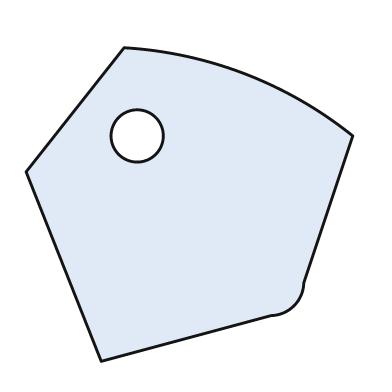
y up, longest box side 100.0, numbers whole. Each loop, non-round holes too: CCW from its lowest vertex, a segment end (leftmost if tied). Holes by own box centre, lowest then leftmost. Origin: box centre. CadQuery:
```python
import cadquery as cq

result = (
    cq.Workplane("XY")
    .moveTo(-27.0, -48.0)
    .lineTo(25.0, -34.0)
    .threePointArc((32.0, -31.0), (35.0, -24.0))
    .lineTo(50.0, 21.0)
    .threePointArc((17.0, 40.0), (-20.0, 48.0))
    .lineTo(-50.0, 10.0)
    .close()
    .moveTo(-16.0, 21.0)
    .circle(8.0)
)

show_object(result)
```